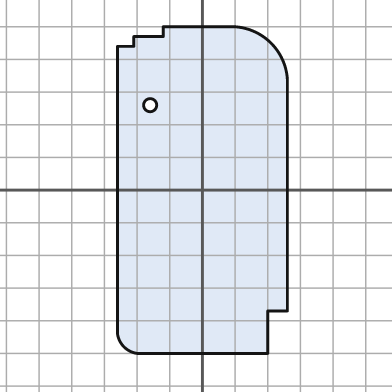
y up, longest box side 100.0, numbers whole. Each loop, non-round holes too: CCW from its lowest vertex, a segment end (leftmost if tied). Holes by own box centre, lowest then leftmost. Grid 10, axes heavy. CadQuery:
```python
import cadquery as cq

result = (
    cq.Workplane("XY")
    .moveTo(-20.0, -50.0)
    .lineTo(20.0, -50.0)
    .lineTo(20.0, -37.0)
    .lineTo(26.0, -37.0)
    .lineTo(26.0, 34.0)
    .threePointArc((21.0, 45.0), (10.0, 50.0))
    .lineTo(-12.0, 50.0)
    .lineTo(-12.0, 47.0)
    .lineTo(-21.0, 47.0)
    .lineTo(-21.0, 44.0)
    .lineTo(-26.0, 44.0)
    .lineTo(-26.0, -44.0)
    .threePointArc((-24.0, -48.0), (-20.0, -50.0))
    .close()
    .moveTo(-16.0, 26.0)
    .circle(2.0)
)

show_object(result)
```